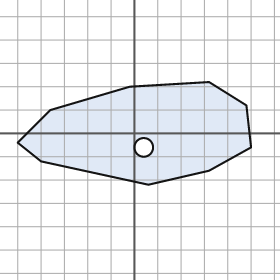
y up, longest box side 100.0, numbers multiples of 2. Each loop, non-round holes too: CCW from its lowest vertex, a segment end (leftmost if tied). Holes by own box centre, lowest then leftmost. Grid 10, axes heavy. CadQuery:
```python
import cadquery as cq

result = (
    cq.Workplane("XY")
    .moveTo(6.0, -22.0)
    .lineTo(32.0, -16.0)
    .lineTo(50.0, -6.0)
    .lineTo(48.0, 12.0)
    .lineTo(32.0, 22.0)
    .lineTo(-2.0, 20.0)
    .lineTo(-36.0, 10.0)
    .lineTo(-50.0, -4.0)
    .lineTo(-40.0, -12.0)
    .close()
    .moveTo(4.0, -6.0)
    .circle(4.0)
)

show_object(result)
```